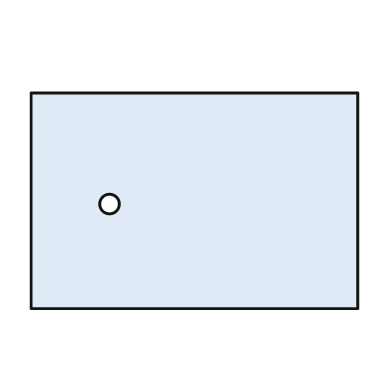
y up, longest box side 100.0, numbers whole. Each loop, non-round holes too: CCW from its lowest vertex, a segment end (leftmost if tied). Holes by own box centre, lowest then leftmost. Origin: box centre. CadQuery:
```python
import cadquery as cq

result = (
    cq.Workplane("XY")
    .moveTo(-50.0, -33.0)
    .lineTo(50.0, -33.0)
    .lineTo(50.0, 33.0)
    .lineTo(-50.0, 33.0)
    .close()
    .moveTo(-26.0, -1.0)
    .circle(3.0)
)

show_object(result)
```